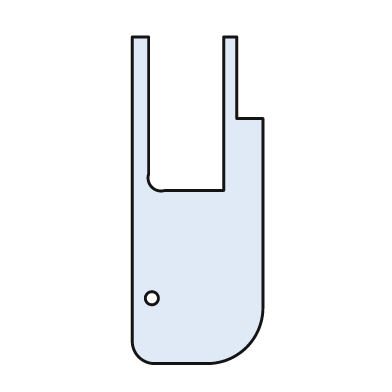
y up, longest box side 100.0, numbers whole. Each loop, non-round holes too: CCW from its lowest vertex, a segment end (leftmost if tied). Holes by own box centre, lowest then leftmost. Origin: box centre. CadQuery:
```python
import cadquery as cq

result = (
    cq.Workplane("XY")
    .moveTo(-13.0, -50.0)
    .lineTo(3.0, -50.0)
    .threePointArc((15.0, -45.0), (20.0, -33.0))
    .lineTo(20.0, 25.0)
    .lineTo(12.0, 25.0)
    .lineTo(12.0, 50.0)
    .lineTo(8.0, 50.0)
    .lineTo(8.0, 3.0)
    .lineTo(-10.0, 3.0)
    .threePointArc((-14.0, 4.0), (-15.0, 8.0))
    .lineTo(-15.0, 50.0)
    .lineTo(-20.0, 50.0)
    .lineTo(-20.0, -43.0)
    .threePointArc((-18.0, -48.0), (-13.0, -50.0))
    .close()
    .moveTo(-14.0, -30.0)
    .circle(2.0)
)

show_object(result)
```